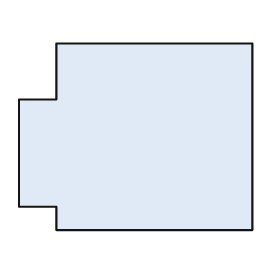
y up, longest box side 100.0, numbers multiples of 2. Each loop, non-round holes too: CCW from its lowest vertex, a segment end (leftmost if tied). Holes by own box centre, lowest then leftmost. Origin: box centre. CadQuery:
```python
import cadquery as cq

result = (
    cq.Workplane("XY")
    .moveTo(-34.0, -40.0)
    .lineTo(50.0, -40.0)
    .lineTo(50.0, 40.0)
    .lineTo(-34.0, 40.0)
    .lineTo(-34.0, 16.0)
    .lineTo(-50.0, 16.0)
    .lineTo(-50.0, -30.0)
    .lineTo(-34.0, -30.0)
    .close()
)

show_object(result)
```